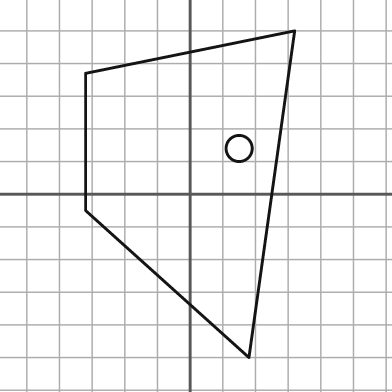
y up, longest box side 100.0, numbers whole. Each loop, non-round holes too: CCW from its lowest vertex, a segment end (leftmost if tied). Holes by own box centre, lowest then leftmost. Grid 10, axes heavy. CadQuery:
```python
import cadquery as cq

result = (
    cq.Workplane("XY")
    .moveTo(18.0, -50.0)
    .lineTo(32.0, 50.0)
    .lineTo(-32.0, 37.0)
    .lineTo(-32.0, -5.0)
    .close()
    .moveTo(15.0, 14.0)
    .circle(4.0)
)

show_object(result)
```